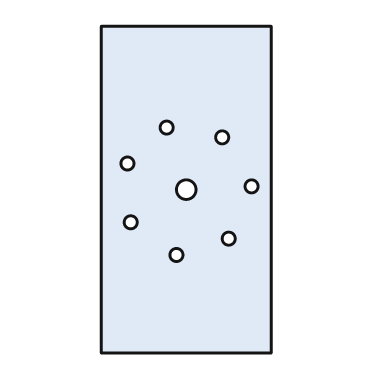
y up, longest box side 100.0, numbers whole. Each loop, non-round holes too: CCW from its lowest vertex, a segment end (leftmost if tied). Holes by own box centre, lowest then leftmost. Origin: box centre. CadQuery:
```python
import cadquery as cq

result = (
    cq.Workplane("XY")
    .moveTo(-26.0, -50.0)
    .lineTo(26.0, -50.0)
    .lineTo(26.0, 50.0)
    .lineTo(-26.0, 50.0)
    .close()
    .moveTo(-3.0, -20.0)
    .circle(2.0)
    .moveTo(13.0, -15.0)
    .circle(2.0)
    .moveTo(-17.0, -10.0)
    .circle(2.0)
    .moveTo(0.0, 0.0)
    .circle(3.0)
    .moveTo(20.0, 1.0)
    .circle(2.0)
    .moveTo(-18.0, 8.0)
    .circle(2.0)
    .moveTo(11.0, 16.0)
    .circle(2.0)
    .moveTo(-6.0, 19.0)
    .circle(2.0)
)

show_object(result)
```